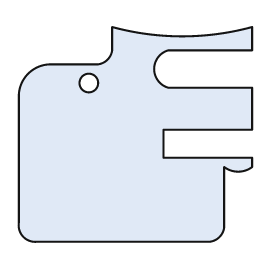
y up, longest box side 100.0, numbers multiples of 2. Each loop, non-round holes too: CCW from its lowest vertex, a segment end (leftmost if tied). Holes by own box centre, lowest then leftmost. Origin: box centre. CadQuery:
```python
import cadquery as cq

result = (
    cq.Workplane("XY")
    .moveTo(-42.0, -46.0)
    .lineTo(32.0, -46.0)
    .threePointArc((36.0, -44.0), (38.0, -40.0))
    .lineTo(38.0, -14.0)
    .threePointArc((44.0, -16.0), (50.0, -14.0))
    .lineTo(50.0, -10.0)
    .lineTo(12.0, -10.0)
    .lineTo(12.0, 2.0)
    .lineTo(50.0, 2.0)
    .lineTo(50.0, 20.0)
    .lineTo(14.0, 20.0)
    .threePointArc((8.0, 28.0), (14.0, 36.0))
    .lineTo(50.0, 36.0)
    .lineTo(50.0, 46.0)
    .threePointArc((20.0, 42.0), (-10.0, 46.0))
    .lineTo(-10.0, 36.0)
    .threePointArc((-12.0, 32.0), (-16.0, 30.0))
    .lineTo(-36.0, 30.0)
    .threePointArc((-46.0, 26.0), (-50.0, 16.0))
    .lineTo(-50.0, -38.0)
    .threePointArc((-48.0, -44.0), (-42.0, -46.0))
    .close()
    .moveTo(-20.0, 22.0)
    .circle(4.0)
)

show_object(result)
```